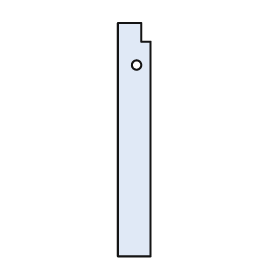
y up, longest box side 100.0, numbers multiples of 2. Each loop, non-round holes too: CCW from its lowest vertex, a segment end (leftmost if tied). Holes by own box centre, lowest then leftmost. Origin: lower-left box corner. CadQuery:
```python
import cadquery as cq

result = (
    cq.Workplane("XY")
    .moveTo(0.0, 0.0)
    .lineTo(14.0, 0.0)
    .lineTo(14.0, 92.0)
    .lineTo(10.0, 92.0)
    .lineTo(10.0, 100.0)
    .lineTo(0.0, 100.0)
    .close()
    .moveTo(8.0, 82.0)
    .circle(2.0)
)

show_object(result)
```